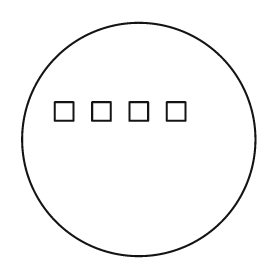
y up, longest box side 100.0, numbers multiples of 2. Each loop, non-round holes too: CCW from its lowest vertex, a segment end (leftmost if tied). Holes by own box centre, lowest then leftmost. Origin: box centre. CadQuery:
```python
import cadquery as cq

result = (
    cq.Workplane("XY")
    .moveTo(0.0, 0.0)
    .circle(50.0)
    .moveTo(-36.0, 8.0)
    .lineTo(-28.0, 8.0)
    .lineTo(-28.0, 16.0)
    .lineTo(-36.0, 16.0)
    .close()
    .moveTo(-20.0, 8.0)
    .lineTo(-12.0, 8.0)
    .lineTo(-12.0, 16.0)
    .lineTo(-20.0, 16.0)
    .close()
    .moveTo(-4.0, 8.0)
    .lineTo(4.0, 8.0)
    .lineTo(4.0, 16.0)
    .lineTo(-4.0, 16.0)
    .close()
    .moveTo(12.0, 8.0)
    .lineTo(20.0, 8.0)
    .lineTo(20.0, 16.0)
    .lineTo(12.0, 16.0)
    .close()
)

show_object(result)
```